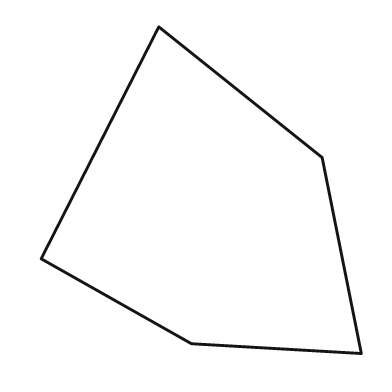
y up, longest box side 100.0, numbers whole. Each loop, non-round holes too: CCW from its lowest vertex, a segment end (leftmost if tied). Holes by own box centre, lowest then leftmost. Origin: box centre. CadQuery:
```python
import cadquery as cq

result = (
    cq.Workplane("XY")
    .moveTo(49.0, -50.0)
    .lineTo(37.0, 10.0)
    .lineTo(-13.0, 50.0)
    .lineTo(-49.0, -21.0)
    .lineTo(-3.0, -47.0)
    .close()
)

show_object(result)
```